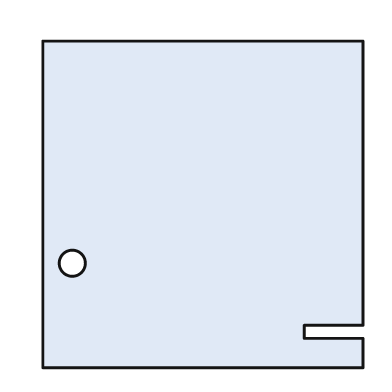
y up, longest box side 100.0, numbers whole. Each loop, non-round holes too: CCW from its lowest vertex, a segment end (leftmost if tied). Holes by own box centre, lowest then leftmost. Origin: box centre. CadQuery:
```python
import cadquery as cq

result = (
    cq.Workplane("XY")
    .moveTo(-49.0, -50.0)
    .lineTo(49.0, -50.0)
    .lineTo(49.0, -41.0)
    .lineTo(31.0, -41.0)
    .lineTo(31.0, -37.0)
    .lineTo(49.0, -37.0)
    .lineTo(49.0, 50.0)
    .lineTo(-49.0, 50.0)
    .close()
    .moveTo(-40.0, -18.0)
    .circle(4.0)
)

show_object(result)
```